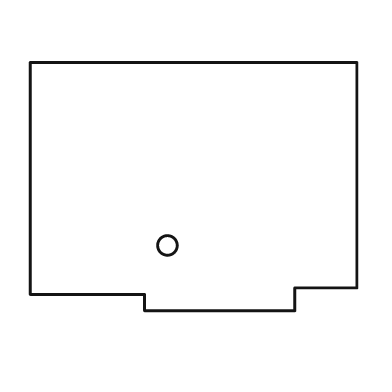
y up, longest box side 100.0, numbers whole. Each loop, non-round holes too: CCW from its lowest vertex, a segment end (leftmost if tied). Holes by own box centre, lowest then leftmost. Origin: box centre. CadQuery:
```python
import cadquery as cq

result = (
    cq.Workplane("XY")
    .moveTo(-15.0, -38.0)
    .lineTo(31.0, -38.0)
    .lineTo(31.0, -31.0)
    .lineTo(50.0, -31.0)
    .lineTo(50.0, 38.0)
    .lineTo(-50.0, 38.0)
    .lineTo(-50.0, -33.0)
    .lineTo(-15.0, -33.0)
    .close()
    .moveTo(-8.0, -18.0)
    .circle(3.0)
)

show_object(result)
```